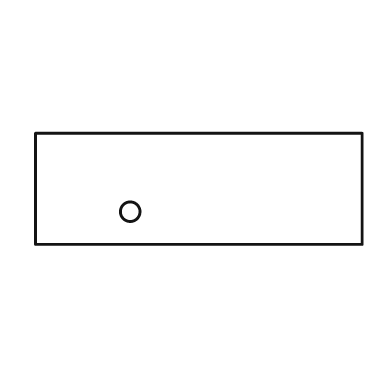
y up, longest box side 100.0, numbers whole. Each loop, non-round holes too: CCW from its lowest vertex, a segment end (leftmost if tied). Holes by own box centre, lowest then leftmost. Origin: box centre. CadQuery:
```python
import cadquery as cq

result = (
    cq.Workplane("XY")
    .moveTo(-50.0, -17.0)
    .lineTo(50.0, -17.0)
    .lineTo(50.0, 17.0)
    .lineTo(-50.0, 17.0)
    .close()
    .moveTo(-21.0, -7.0)
    .circle(3.0)
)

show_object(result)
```